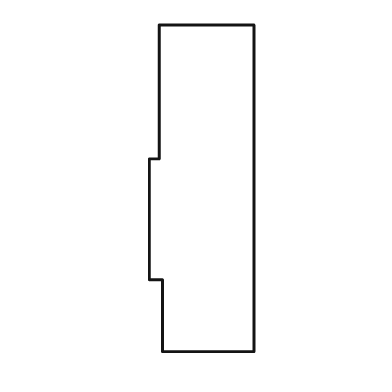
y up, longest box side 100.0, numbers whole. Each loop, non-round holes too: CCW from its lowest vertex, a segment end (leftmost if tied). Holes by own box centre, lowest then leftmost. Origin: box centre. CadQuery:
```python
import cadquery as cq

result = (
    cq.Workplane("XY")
    .moveTo(-12.0, -50.0)
    .lineTo(16.0, -50.0)
    .lineTo(16.0, 50.0)
    .lineTo(-13.0, 50.0)
    .lineTo(-13.0, 9.0)
    .lineTo(-16.0, 9.0)
    .lineTo(-16.0, -28.0)
    .lineTo(-12.0, -28.0)
    .close()
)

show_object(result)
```